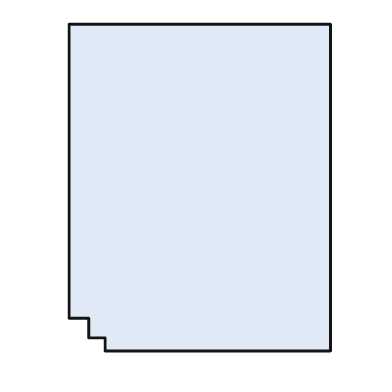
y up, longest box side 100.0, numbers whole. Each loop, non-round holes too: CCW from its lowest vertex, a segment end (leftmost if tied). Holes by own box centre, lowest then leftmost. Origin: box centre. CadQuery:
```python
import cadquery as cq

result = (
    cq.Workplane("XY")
    .moveTo(-29.0, -50.0)
    .lineTo(40.0, -50.0)
    .lineTo(40.0, 50.0)
    .lineTo(-40.0, 50.0)
    .lineTo(-40.0, -40.0)
    .lineTo(-34.0, -40.0)
    .lineTo(-34.0, -46.0)
    .lineTo(-29.0, -46.0)
    .close()
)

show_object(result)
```